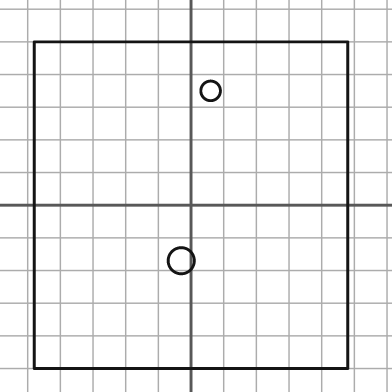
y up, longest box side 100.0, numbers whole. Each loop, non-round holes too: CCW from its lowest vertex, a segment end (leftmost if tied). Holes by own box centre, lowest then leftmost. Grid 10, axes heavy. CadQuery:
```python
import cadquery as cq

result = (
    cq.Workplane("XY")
    .moveTo(-48.0, -50.0)
    .lineTo(48.0, -50.0)
    .lineTo(48.0, 50.0)
    .lineTo(-48.0, 50.0)
    .close()
    .moveTo(-3.0, -17.0)
    .circle(4.0)
    .moveTo(6.0, 35.0)
    .circle(3.0)
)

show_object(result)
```